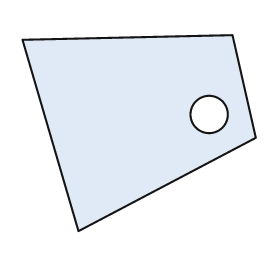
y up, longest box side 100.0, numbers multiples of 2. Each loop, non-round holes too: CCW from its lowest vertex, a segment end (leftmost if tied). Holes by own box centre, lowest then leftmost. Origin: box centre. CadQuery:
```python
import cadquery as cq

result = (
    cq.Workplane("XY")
    .moveTo(-26.0, -42.0)
    .lineTo(50.0, -2.0)
    .lineTo(40.0, 42.0)
    .lineTo(-50.0, 40.0)
    .close()
    .moveTo(30.0, 8.0)
    .circle(8.0)
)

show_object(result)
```